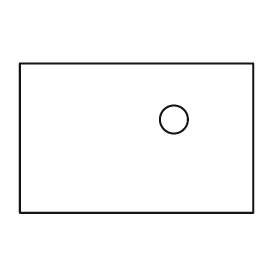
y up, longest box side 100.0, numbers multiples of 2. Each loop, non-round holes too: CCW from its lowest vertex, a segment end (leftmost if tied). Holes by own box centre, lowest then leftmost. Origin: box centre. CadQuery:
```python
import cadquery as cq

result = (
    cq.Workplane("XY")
    .moveTo(-50.0, -32.0)
    .lineTo(50.0, -32.0)
    .lineTo(50.0, 32.0)
    .lineTo(-50.0, 32.0)
    .close()
    .moveTo(16.0, 8.0)
    .circle(6.0)
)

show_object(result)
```